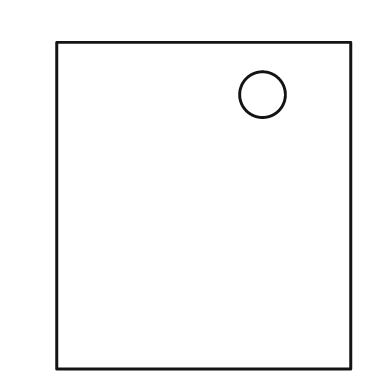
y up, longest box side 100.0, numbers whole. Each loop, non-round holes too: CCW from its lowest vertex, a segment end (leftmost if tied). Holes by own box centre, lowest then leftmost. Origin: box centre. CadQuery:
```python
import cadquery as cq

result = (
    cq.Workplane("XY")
    .moveTo(-45.0, -50.0)
    .lineTo(45.0, -50.0)
    .lineTo(45.0, 50.0)
    .lineTo(-45.0, 50.0)
    .close()
    .moveTo(18.0, 34.0)
    .circle(7.0)
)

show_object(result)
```